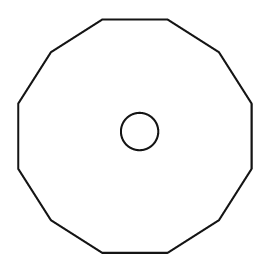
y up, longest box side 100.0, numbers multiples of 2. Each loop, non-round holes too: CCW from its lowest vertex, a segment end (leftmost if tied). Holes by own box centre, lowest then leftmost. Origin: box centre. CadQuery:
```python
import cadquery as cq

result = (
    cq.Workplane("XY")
    .moveTo(-14.0, -50.0)
    .lineTo(14.0, -50.0)
    .lineTo(36.0, -36.0)
    .lineTo(50.0, -14.0)
    .lineTo(50.0, 14.0)
    .lineTo(36.0, 36.0)
    .lineTo(14.0, 50.0)
    .lineTo(-14.0, 50.0)
    .lineTo(-36.0, 36.0)
    .lineTo(-50.0, 14.0)
    .lineTo(-50.0, -14.0)
    .lineTo(-36.0, -36.0)
    .close()
    .moveTo(2.0, 2.0)
    .circle(8.0)
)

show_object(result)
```